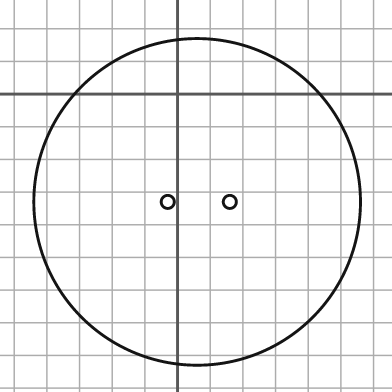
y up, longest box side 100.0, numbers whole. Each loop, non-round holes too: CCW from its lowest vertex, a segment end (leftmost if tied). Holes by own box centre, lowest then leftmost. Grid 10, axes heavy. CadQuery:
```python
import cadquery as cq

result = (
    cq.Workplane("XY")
    .moveTo(6.0, -33.0)
    .circle(50.0)
    .moveTo(-3.0, -33.0)
    .circle(2.0)
    .moveTo(16.0, -33.0)
    .circle(2.0)
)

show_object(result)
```